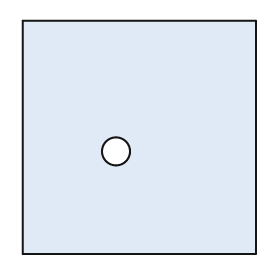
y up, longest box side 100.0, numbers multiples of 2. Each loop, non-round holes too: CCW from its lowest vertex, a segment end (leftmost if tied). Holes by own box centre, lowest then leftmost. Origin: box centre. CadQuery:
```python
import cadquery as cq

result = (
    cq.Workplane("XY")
    .moveTo(-50.0, -50.0)
    .lineTo(50.0, -50.0)
    .lineTo(50.0, 50.0)
    .lineTo(-50.0, 50.0)
    .close()
    .moveTo(-10.0, -6.0)
    .circle(6.0)
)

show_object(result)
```